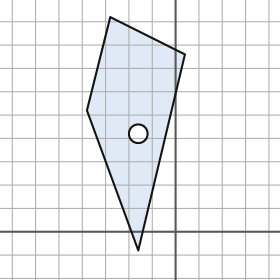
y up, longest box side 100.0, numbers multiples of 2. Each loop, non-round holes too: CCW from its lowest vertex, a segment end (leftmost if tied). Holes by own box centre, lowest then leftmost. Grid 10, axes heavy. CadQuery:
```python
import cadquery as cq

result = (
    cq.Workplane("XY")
    .moveTo(-16.0, -8.0)
    .lineTo(4.0, 76.0)
    .lineTo(-28.0, 92.0)
    .lineTo(-38.0, 52.0)
    .close()
    .moveTo(-16.0, 42.0)
    .circle(4.0)
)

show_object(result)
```